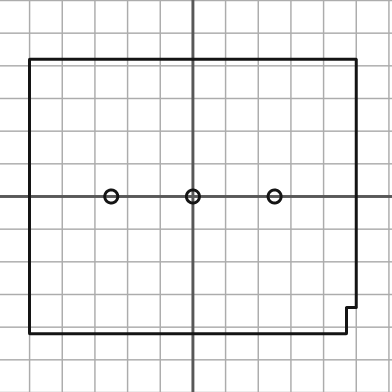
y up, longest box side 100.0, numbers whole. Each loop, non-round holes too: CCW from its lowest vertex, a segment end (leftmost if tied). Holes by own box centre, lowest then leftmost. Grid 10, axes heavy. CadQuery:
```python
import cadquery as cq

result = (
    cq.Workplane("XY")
    .moveTo(-50.0, -42.0)
    .lineTo(47.0, -42.0)
    .lineTo(47.0, -34.0)
    .lineTo(50.0, -34.0)
    .lineTo(50.0, 42.0)
    .lineTo(-50.0, 42.0)
    .close()
    .moveTo(-25.0, 0.0)
    .circle(2.0)
    .moveTo(0.0, 0.0)
    .circle(2.0)
    .moveTo(25.0, 0.0)
    .circle(2.0)
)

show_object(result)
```